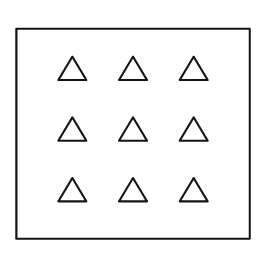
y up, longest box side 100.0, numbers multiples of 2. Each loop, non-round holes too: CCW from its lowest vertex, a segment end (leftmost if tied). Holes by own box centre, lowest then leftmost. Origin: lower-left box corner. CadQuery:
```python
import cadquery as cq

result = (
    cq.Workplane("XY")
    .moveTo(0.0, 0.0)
    .lineTo(100.0, 0.0)
    .lineTo(100.0, 90.0)
    .lineTo(0.0, 90.0)
    .close()
    .moveTo(18.0, 16.0)
    .lineTo(30.0, 16.0)
    .lineTo(24.0, 26.0)
    .close()
    .moveTo(44.0, 16.0)
    .lineTo(56.0, 16.0)
    .lineTo(50.0, 26.0)
    .close()
    .moveTo(70.0, 16.0)
    .lineTo(82.0, 16.0)
    .lineTo(76.0, 26.0)
    .close()
    .moveTo(18.0, 42.0)
    .lineTo(30.0, 42.0)
    .lineTo(24.0, 52.0)
    .close()
    .moveTo(44.0, 42.0)
    .lineTo(56.0, 42.0)
    .lineTo(50.0, 52.0)
    .close()
    .moveTo(70.0, 42.0)
    .lineTo(82.0, 42.0)
    .lineTo(76.0, 52.0)
    .close()
    .moveTo(18.0, 68.0)
    .lineTo(30.0, 68.0)
    .lineTo(24.0, 78.0)
    .close()
    .moveTo(44.0, 68.0)
    .lineTo(56.0, 68.0)
    .lineTo(50.0, 78.0)
    .close()
    .moveTo(70.0, 68.0)
    .lineTo(82.0, 68.0)
    .lineTo(76.0, 78.0)
    .close()
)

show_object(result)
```